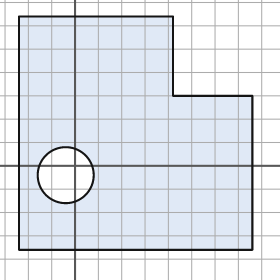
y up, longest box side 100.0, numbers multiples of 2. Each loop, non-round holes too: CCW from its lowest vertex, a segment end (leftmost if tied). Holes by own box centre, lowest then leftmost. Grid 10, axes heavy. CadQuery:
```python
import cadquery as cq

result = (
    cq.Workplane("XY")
    .moveTo(-24.0, -36.0)
    .lineTo(76.0, -36.0)
    .lineTo(76.0, 30.0)
    .lineTo(42.0, 30.0)
    .lineTo(42.0, 64.0)
    .lineTo(-24.0, 64.0)
    .close()
    .moveTo(-4.0, -4.0)
    .circle(12.0)
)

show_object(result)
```